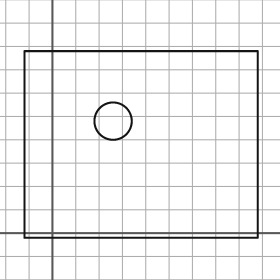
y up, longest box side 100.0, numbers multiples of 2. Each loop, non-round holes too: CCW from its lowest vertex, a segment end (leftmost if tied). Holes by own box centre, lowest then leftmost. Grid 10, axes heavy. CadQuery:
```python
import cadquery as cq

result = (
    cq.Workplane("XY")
    .moveTo(-12.0, -2.0)
    .lineTo(88.0, -2.0)
    .lineTo(88.0, 78.0)
    .lineTo(-12.0, 78.0)
    .close()
    .moveTo(26.0, 48.0)
    .circle(8.0)
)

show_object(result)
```